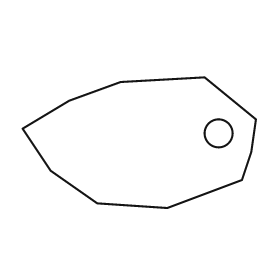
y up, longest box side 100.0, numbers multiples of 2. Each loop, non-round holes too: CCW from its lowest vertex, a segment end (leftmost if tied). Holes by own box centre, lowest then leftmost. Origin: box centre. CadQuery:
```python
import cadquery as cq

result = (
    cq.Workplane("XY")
    .moveTo(12.0, -28.0)
    .lineTo(44.0, -16.0)
    .lineTo(48.0, -4.0)
    .lineTo(50.0, 10.0)
    .lineTo(28.0, 28.0)
    .lineTo(-8.0, 26.0)
    .lineTo(-30.0, 18.0)
    .lineTo(-50.0, 6.0)
    .lineTo(-38.0, -12.0)
    .lineTo(-18.0, -26.0)
    .close()
    .moveTo(34.0, 4.0)
    .circle(6.0)
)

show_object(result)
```